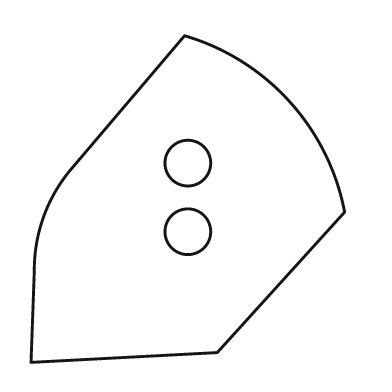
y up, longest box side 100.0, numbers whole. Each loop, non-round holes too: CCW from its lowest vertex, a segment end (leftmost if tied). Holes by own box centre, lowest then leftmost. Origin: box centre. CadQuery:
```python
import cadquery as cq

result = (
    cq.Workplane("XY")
    .moveTo(-48.0, -50.0)
    .lineTo(9.0, -47.0)
    .lineTo(48.0, -4.0)
    .threePointArc((31.0, 30.0), (-1.0, 50.0))
    .lineTo(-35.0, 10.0)
    .threePointArc((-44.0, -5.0), (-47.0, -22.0))
    .close()
    .moveTo(0.0, -10.0)
    .circle(7.0)
    .moveTo(0.0, 11.0)
    .circle(7.0)
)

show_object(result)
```